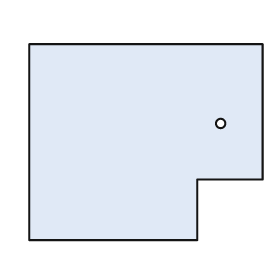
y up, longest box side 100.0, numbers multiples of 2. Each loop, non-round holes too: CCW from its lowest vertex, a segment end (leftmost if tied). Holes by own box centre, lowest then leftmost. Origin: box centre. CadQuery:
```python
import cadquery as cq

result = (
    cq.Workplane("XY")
    .moveTo(-50.0, -42.0)
    .lineTo(22.0, -42.0)
    .lineTo(22.0, -16.0)
    .lineTo(50.0, -16.0)
    .lineTo(50.0, 42.0)
    .lineTo(-50.0, 42.0)
    .close()
    .moveTo(32.0, 8.0)
    .circle(2.0)
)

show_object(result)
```